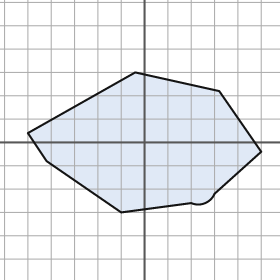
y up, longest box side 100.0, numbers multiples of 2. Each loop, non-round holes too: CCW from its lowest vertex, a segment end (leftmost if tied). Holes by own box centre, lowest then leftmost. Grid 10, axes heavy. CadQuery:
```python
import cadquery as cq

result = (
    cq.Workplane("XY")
    .moveTo(-10.0, -30.0)
    .lineTo(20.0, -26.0)
    .threePointArc((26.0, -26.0), (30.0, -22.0))
    .lineTo(50.0, -4.0)
    .lineTo(32.0, 22.0)
    .lineTo(-4.0, 30.0)
    .lineTo(-50.0, 4.0)
    .lineTo(-42.0, -8.0)
    .close()
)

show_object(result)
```